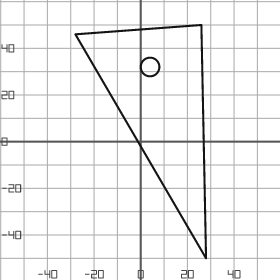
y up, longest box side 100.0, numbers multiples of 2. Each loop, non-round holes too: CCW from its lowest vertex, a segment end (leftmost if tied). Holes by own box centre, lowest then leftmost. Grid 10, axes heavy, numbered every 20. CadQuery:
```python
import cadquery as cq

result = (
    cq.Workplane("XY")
    .moveTo(28.0, -50.0)
    .lineTo(26.0, 50.0)
    .lineTo(-28.0, 46.0)
    .close()
    .moveTo(4.0, 32.0)
    .circle(4.0)
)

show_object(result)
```